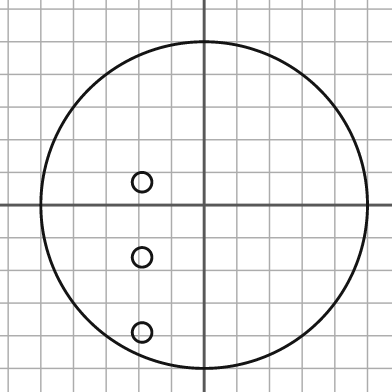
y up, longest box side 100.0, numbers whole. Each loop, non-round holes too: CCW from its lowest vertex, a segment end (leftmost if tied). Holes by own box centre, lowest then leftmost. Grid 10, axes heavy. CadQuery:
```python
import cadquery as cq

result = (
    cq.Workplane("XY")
    .moveTo(0.0, 0.0)
    .circle(50.0)
    .moveTo(-19.0, -39.0)
    .circle(3.0)
    .moveTo(-19.0, -16.0)
    .circle(3.0)
    .moveTo(-19.0, 7.0)
    .circle(3.0)
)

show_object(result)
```